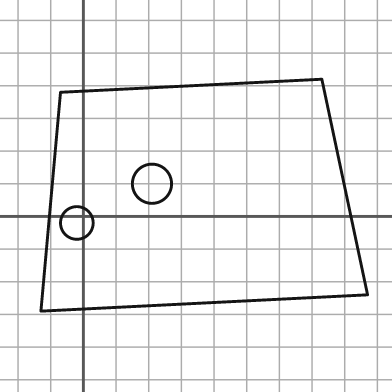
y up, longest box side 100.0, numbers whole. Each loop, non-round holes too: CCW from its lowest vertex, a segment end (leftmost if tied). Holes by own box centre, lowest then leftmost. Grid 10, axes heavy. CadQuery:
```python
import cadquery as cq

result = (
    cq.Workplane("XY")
    .moveTo(-13.0, -29.0)
    .lineTo(87.0, -24.0)
    .lineTo(73.0, 42.0)
    .lineTo(-7.0, 38.0)
    .close()
    .moveTo(-2.0, -2.0)
    .circle(5.0)
    .moveTo(21.0, 10.0)
    .circle(6.0)
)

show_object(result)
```